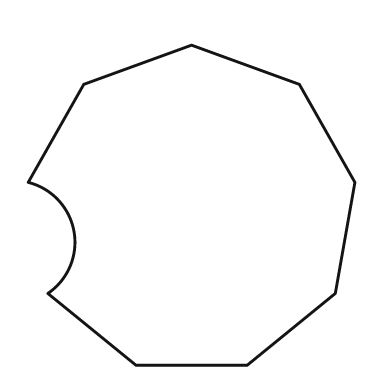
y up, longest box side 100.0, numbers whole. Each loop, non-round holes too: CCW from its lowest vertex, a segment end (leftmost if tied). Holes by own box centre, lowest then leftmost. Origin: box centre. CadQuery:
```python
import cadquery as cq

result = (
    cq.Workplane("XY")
    .moveTo(-17.0, -49.0)
    .lineTo(17.0, -49.0)
    .lineTo(44.0, -27.0)
    .lineTo(50.0, 7.0)
    .lineTo(33.0, 37.0)
    .lineTo(0.0, 49.0)
    .lineTo(-33.0, 37.0)
    .lineTo(-50.0, 7.0)
    .threePointArc((-36.0, -8.0), (-44.0, -27.0))
    .close()
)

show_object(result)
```